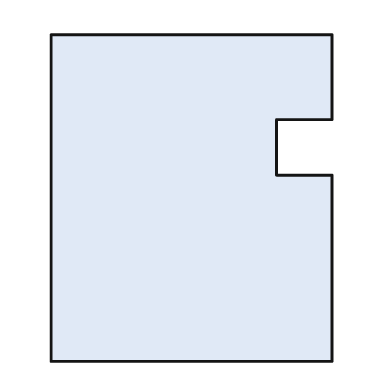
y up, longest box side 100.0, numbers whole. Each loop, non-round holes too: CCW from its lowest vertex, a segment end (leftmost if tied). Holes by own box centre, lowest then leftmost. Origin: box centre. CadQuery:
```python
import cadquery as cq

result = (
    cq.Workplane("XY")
    .moveTo(-43.0, -50.0)
    .lineTo(43.0, -50.0)
    .lineTo(43.0, 7.0)
    .lineTo(26.0, 7.0)
    .lineTo(26.0, 24.0)
    .lineTo(43.0, 24.0)
    .lineTo(43.0, 50.0)
    .lineTo(-43.0, 50.0)
    .close()
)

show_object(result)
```